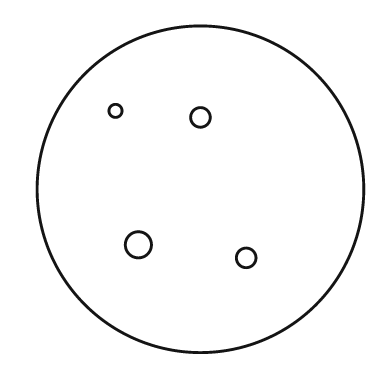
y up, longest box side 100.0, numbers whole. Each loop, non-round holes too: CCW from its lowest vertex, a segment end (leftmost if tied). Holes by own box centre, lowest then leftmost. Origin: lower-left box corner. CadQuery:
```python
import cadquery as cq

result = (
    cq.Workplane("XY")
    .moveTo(50.0, 50.0)
    .circle(50.0)
    .moveTo(64.0, 29.0)
    .circle(3.0)
    .moveTo(31.0, 33.0)
    .circle(4.0)
    .moveTo(50.0, 72.0)
    .circle(3.0)
    .moveTo(24.0, 74.0)
    .circle(2.0)
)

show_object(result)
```